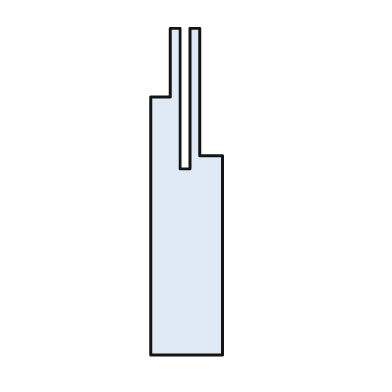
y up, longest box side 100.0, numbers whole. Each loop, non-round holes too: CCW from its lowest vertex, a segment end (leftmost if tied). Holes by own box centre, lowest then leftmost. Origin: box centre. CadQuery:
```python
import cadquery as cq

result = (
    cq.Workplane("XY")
    .moveTo(-11.0, -50.0)
    .lineTo(11.0, -50.0)
    .lineTo(11.0, 11.0)
    .lineTo(4.0, 11.0)
    .lineTo(4.0, 50.0)
    .lineTo(1.0, 50.0)
    .lineTo(1.0, 7.0)
    .lineTo(-2.0, 7.0)
    .lineTo(-2.0, 50.0)
    .lineTo(-5.0, 50.0)
    .lineTo(-5.0, 29.0)
    .lineTo(-11.0, 29.0)
    .close()
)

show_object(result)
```